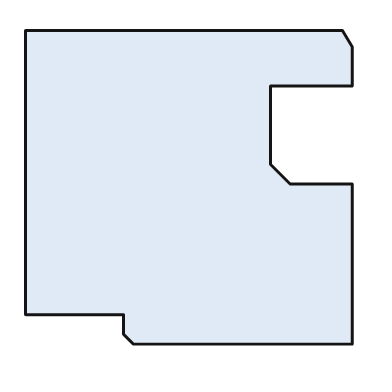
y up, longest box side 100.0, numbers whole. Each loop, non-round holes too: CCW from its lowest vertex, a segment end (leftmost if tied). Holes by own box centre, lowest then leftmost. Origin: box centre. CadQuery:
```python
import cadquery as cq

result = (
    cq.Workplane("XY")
    .moveTo(-17.0, -48.0)
    .lineTo(50.0, -48.0)
    .lineTo(50.0, 1.0)
    .lineTo(31.0, 1.0)
    .lineTo(25.0, 7.0)
    .lineTo(25.0, 31.0)
    .lineTo(50.0, 31.0)
    .lineTo(50.0, 43.0)
    .lineTo(47.0, 48.0)
    .lineTo(-50.0, 48.0)
    .lineTo(-50.0, -39.0)
    .lineTo(-20.0, -39.0)
    .lineTo(-20.0, -45.0)
    .close()
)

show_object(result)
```